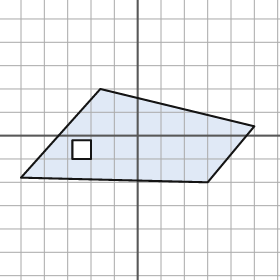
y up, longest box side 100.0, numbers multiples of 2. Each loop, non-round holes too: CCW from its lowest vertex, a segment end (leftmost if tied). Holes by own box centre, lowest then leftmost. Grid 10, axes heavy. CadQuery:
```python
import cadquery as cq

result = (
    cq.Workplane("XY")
    .moveTo(30.0, -20.0)
    .lineTo(50.0, 4.0)
    .lineTo(-16.0, 20.0)
    .lineTo(-50.0, -18.0)
    .close()
    .moveTo(-28.0, -10.0)
    .lineTo(-20.0, -10.0)
    .lineTo(-20.0, -2.0)
    .lineTo(-28.0, -2.0)
    .close()
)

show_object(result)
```